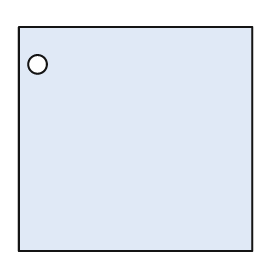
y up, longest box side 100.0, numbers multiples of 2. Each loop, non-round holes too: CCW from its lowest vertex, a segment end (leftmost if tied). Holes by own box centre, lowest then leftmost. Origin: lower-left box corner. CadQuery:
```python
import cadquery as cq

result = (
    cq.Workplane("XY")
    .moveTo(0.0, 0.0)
    .lineTo(100.0, 0.0)
    .lineTo(100.0, 96.0)
    .lineTo(0.0, 96.0)
    .close()
    .moveTo(8.0, 80.0)
    .circle(4.0)
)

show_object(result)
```